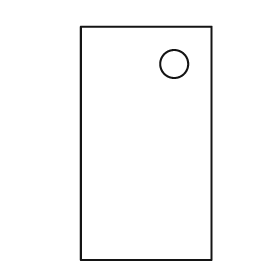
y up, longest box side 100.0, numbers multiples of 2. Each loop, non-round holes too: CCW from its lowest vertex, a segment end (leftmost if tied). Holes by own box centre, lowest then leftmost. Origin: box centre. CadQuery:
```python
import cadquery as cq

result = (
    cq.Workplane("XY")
    .moveTo(-28.0, -50.0)
    .lineTo(28.0, -50.0)
    .lineTo(28.0, 50.0)
    .lineTo(-28.0, 50.0)
    .close()
    .moveTo(12.0, 34.0)
    .circle(6.0)
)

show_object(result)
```